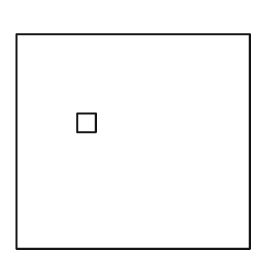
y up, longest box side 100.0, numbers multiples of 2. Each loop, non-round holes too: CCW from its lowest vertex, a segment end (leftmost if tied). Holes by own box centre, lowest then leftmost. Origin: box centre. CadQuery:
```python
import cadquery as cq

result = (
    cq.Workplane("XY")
    .moveTo(-50.0, -46.0)
    .lineTo(50.0, -46.0)
    .lineTo(50.0, 46.0)
    .lineTo(-50.0, 46.0)
    .close()
    .moveTo(-24.0, 4.0)
    .lineTo(-16.0, 4.0)
    .lineTo(-16.0, 12.0)
    .lineTo(-24.0, 12.0)
    .close()
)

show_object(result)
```